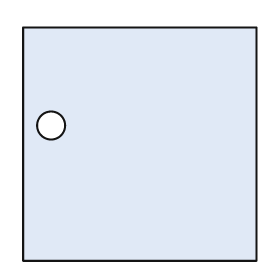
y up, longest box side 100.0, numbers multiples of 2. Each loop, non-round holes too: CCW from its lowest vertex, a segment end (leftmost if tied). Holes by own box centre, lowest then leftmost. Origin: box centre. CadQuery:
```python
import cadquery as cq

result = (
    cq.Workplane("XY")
    .moveTo(-50.0, -50.0)
    .lineTo(50.0, -50.0)
    .lineTo(50.0, 50.0)
    .lineTo(-50.0, 50.0)
    .close()
    .moveTo(-38.0, 8.0)
    .circle(6.0)
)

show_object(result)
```